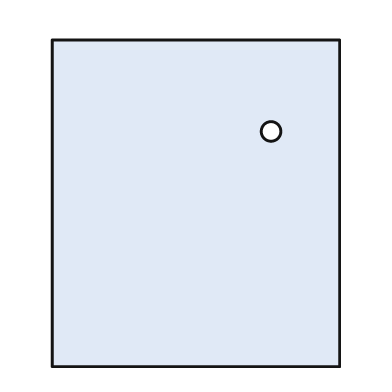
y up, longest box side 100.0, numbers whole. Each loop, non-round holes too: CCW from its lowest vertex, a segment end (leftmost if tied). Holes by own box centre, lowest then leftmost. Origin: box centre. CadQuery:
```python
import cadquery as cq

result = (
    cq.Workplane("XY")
    .moveTo(-44.0, -50.0)
    .lineTo(44.0, -50.0)
    .lineTo(44.0, 50.0)
    .lineTo(-44.0, 50.0)
    .close()
    .moveTo(23.0, 22.0)
    .circle(3.0)
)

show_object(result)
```